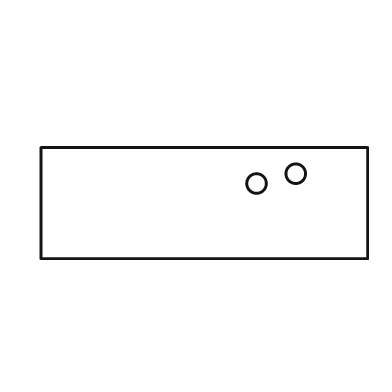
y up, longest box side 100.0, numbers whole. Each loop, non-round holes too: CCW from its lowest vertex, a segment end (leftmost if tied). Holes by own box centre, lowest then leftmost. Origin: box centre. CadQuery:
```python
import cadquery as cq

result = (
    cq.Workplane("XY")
    .moveTo(-50.0, -17.0)
    .lineTo(50.0, -17.0)
    .lineTo(50.0, 17.0)
    .lineTo(-50.0, 17.0)
    .close()
    .moveTo(16.0, 6.0)
    .circle(3.0)
    .moveTo(28.0, 9.0)
    .circle(3.0)
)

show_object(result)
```